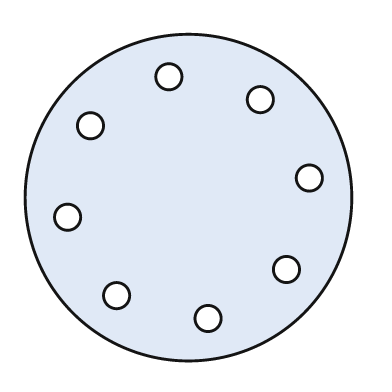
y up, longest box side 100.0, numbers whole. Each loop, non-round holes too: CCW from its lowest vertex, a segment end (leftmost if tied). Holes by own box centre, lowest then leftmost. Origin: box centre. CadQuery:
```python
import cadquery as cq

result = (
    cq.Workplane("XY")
    .moveTo(0.0, 0.0)
    .circle(50.0)
    .moveTo(6.0, -37.0)
    .circle(4.0)
    .moveTo(-22.0, -30.0)
    .circle(4.0)
    .moveTo(30.0, -22.0)
    .circle(4.0)
    .moveTo(-37.0, -6.0)
    .circle(4.0)
    .moveTo(37.0, 6.0)
    .circle(4.0)
    .moveTo(-30.0, 22.0)
    .circle(4.0)
    .moveTo(22.0, 30.0)
    .circle(4.0)
    .moveTo(-6.0, 37.0)
    .circle(4.0)
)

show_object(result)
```